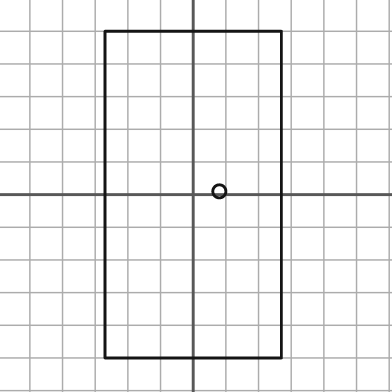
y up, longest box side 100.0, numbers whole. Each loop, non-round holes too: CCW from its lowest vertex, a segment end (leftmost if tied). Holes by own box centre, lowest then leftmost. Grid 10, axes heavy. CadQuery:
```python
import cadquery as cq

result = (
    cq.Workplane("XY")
    .moveTo(-27.0, -50.0)
    .lineTo(27.0, -50.0)
    .lineTo(27.0, 50.0)
    .lineTo(-27.0, 50.0)
    .close()
    .moveTo(8.0, 1.0)
    .circle(2.0)
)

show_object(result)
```